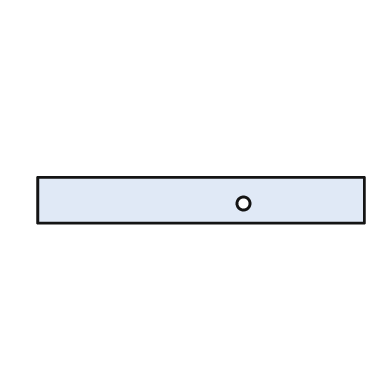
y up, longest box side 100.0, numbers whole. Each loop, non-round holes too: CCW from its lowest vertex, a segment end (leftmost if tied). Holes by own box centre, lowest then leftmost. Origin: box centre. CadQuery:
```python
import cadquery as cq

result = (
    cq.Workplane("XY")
    .moveTo(-50.0, -7.0)
    .lineTo(50.0, -7.0)
    .lineTo(50.0, 7.0)
    .lineTo(-50.0, 7.0)
    .close()
    .moveTo(13.0, -1.0)
    .circle(2.0)
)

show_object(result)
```